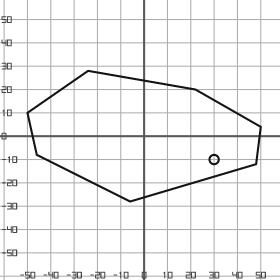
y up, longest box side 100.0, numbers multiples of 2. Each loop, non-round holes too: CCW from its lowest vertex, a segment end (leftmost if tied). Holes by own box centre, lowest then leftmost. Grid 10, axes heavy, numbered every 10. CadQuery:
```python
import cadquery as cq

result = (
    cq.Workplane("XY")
    .moveTo(-6.0, -28.0)
    .lineTo(48.0, -12.0)
    .lineTo(50.0, 4.0)
    .lineTo(22.0, 20.0)
    .lineTo(-24.0, 28.0)
    .lineTo(-50.0, 10.0)
    .lineTo(-46.0, -8.0)
    .close()
    .moveTo(30.0, -10.0)
    .circle(2.0)
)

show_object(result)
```